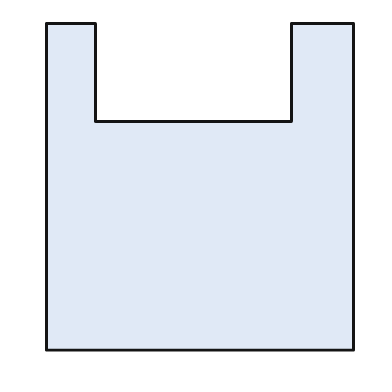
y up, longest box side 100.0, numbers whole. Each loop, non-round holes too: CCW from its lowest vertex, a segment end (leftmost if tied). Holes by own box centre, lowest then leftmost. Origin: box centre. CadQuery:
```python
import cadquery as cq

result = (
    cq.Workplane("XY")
    .moveTo(-47.0, -50.0)
    .lineTo(47.0, -50.0)
    .lineTo(47.0, 50.0)
    .lineTo(28.0, 50.0)
    .lineTo(28.0, 20.0)
    .lineTo(-32.0, 20.0)
    .lineTo(-32.0, 50.0)
    .lineTo(-47.0, 50.0)
    .close()
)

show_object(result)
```